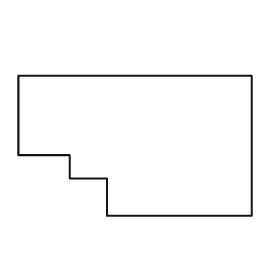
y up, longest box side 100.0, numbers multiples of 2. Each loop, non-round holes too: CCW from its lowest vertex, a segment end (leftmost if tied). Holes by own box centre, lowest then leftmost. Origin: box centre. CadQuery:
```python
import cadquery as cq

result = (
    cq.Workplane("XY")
    .moveTo(-12.0, -30.0)
    .lineTo(50.0, -30.0)
    .lineTo(50.0, 30.0)
    .lineTo(-50.0, 30.0)
    .lineTo(-50.0, -4.0)
    .lineTo(-28.0, -4.0)
    .lineTo(-28.0, -14.0)
    .lineTo(-12.0, -14.0)
    .close()
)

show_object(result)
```